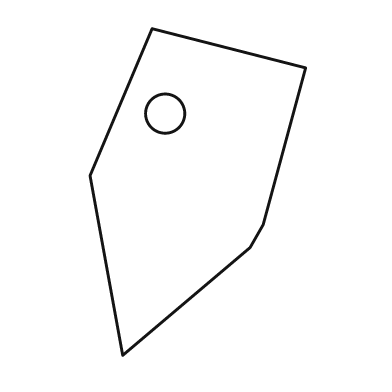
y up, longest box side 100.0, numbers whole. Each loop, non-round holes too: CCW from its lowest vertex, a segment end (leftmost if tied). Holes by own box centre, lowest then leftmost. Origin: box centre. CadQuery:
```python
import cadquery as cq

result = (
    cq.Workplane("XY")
    .moveTo(-23.0, -50.0)
    .lineTo(16.0, -17.0)
    .lineTo(20.0, -10.0)
    .lineTo(33.0, 38.0)
    .lineTo(-14.0, 50.0)
    .lineTo(-33.0, 5.0)
    .close()
    .moveTo(-10.0, 24.0)
    .circle(6.0)
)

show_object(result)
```